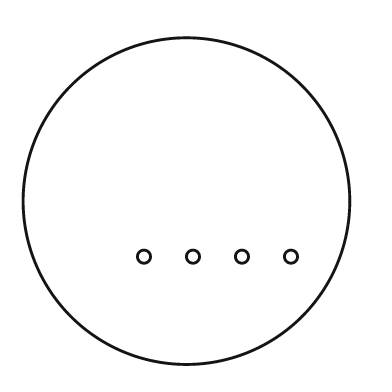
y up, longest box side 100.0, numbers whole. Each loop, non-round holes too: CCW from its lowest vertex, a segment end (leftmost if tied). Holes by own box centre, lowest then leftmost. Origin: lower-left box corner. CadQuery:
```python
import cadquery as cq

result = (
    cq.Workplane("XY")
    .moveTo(50.0, 50.0)
    .circle(50.0)
    .moveTo(37.0, 33.0)
    .circle(2.0)
    .moveTo(52.0, 33.0)
    .circle(2.0)
    .moveTo(67.0, 33.0)
    .circle(2.0)
    .moveTo(82.0, 33.0)
    .circle(2.0)
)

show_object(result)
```